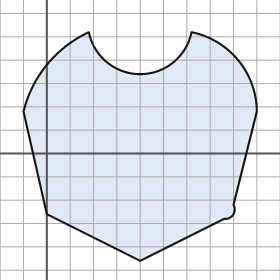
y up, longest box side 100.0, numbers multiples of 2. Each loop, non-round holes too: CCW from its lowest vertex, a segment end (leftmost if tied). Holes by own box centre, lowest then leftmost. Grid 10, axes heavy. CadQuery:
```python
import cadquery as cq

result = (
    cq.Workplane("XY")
    .moveTo(40.0, -46.0)
    .lineTo(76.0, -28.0)
    .threePointArc((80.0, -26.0), (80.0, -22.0))
    .lineTo(90.0, 18.0)
    .threePointArc((82.0, 40.0), (62.0, 52.0))
    .threePointArc((40.0, 34.0), (18.0, 52.0))
    .threePointArc((0.0, 38.0), (-10.0, 18.0))
    .lineTo(0.0, -26.0)
    .close()
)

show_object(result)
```